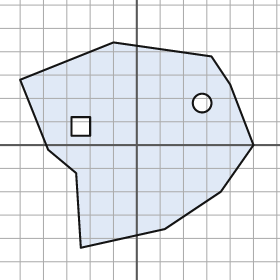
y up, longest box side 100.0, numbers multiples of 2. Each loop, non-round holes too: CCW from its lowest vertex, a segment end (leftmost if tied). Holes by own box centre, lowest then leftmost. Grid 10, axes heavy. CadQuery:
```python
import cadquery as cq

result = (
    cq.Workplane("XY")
    .moveTo(-24.0, -44.0)
    .lineTo(12.0, -36.0)
    .lineTo(36.0, -20.0)
    .lineTo(50.0, 0.0)
    .lineTo(40.0, 26.0)
    .lineTo(32.0, 38.0)
    .lineTo(-10.0, 44.0)
    .lineTo(-50.0, 28.0)
    .lineTo(-38.0, -2.0)
    .lineTo(-26.0, -12.0)
    .close()
    .moveTo(-28.0, 4.0)
    .lineTo(-20.0, 4.0)
    .lineTo(-20.0, 12.0)
    .lineTo(-28.0, 12.0)
    .close()
    .moveTo(28.0, 18.0)
    .circle(4.0)
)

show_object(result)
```